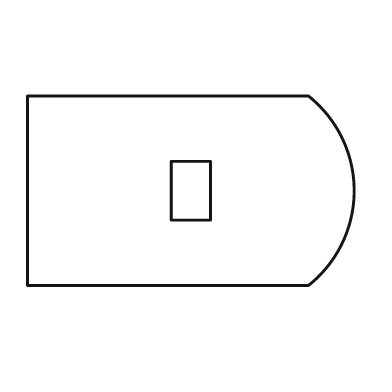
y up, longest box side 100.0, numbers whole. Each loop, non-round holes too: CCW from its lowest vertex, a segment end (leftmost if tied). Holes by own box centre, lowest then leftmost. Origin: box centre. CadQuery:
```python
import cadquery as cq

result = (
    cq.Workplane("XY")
    .moveTo(-50.0, -29.0)
    .lineTo(36.0, -29.0)
    .threePointArc((50.0, 0.0), (36.0, 29.0))
    .lineTo(-50.0, 29.0)
    .close()
    .moveTo(-6.0, -9.0)
    .lineTo(6.0, -9.0)
    .lineTo(6.0, 9.0)
    .lineTo(-6.0, 9.0)
    .close()
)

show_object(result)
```